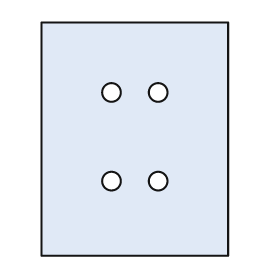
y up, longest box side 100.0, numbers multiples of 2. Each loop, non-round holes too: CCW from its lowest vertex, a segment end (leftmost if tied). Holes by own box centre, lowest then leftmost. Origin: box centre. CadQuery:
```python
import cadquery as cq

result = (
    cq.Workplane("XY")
    .moveTo(-40.0, -50.0)
    .lineTo(40.0, -50.0)
    .lineTo(40.0, 50.0)
    .lineTo(-40.0, 50.0)
    .close()
    .moveTo(-10.0, -18.0)
    .circle(4.0)
    .moveTo(10.0, -18.0)
    .circle(4.0)
    .moveTo(-10.0, 20.0)
    .circle(4.0)
    .moveTo(10.0, 20.0)
    .circle(4.0)
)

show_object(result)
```